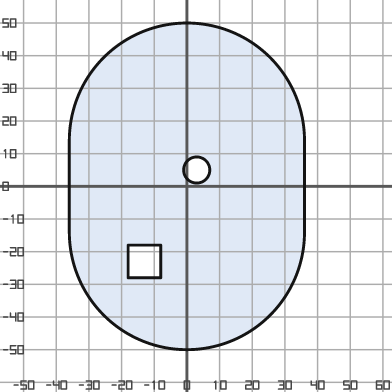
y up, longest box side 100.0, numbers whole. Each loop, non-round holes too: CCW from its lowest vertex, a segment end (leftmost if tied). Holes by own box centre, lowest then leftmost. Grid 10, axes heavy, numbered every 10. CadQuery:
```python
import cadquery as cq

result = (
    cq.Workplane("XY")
    .moveTo(-36.0, -14.0)
    .threePointArc((0.0, -50.0), (36.0, -14.0))
    .lineTo(36.0, 14.0)
    .threePointArc((0.0, 50.0), (-36.0, 14.0))
    .close()
    .moveTo(-18.0, -28.0)
    .lineTo(-8.0, -28.0)
    .lineTo(-8.0, -18.0)
    .lineTo(-18.0, -18.0)
    .close()
    .moveTo(3.0, 5.0)
    .circle(4.0)
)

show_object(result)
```